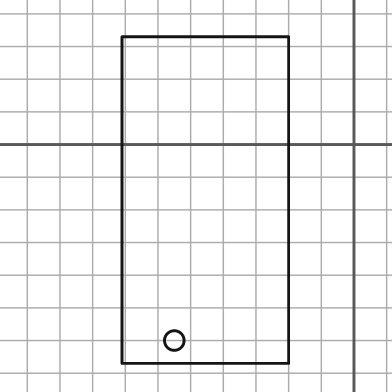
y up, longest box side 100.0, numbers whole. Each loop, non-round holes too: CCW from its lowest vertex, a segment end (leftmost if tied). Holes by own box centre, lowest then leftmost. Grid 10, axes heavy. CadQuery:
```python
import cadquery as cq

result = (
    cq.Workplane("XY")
    .moveTo(-71.0, -67.0)
    .lineTo(-20.0, -67.0)
    .lineTo(-20.0, 33.0)
    .lineTo(-71.0, 33.0)
    .close()
    .moveTo(-55.0, -60.0)
    .circle(3.0)
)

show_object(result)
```